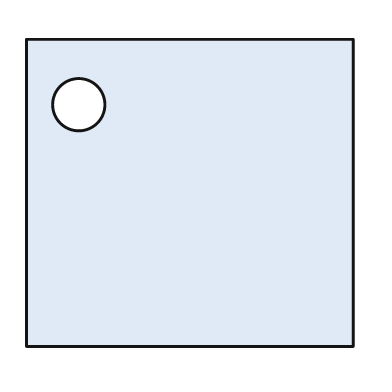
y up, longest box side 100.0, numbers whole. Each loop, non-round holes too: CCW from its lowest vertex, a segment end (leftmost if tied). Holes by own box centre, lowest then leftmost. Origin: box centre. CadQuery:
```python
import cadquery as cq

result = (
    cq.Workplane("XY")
    .moveTo(-50.0, -47.0)
    .lineTo(50.0, -47.0)
    .lineTo(50.0, 47.0)
    .lineTo(-50.0, 47.0)
    .close()
    .moveTo(-34.0, 27.0)
    .circle(8.0)
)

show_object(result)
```